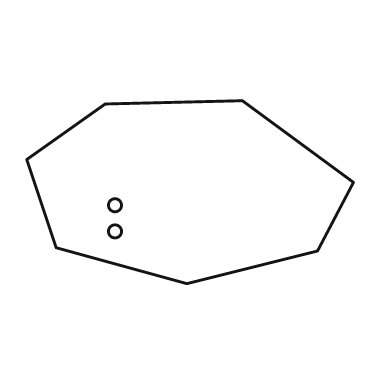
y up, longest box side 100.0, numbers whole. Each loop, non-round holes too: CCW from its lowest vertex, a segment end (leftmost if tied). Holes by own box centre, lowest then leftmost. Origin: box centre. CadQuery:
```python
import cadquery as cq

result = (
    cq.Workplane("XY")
    .moveTo(-1.0, -28.0)
    .lineTo(39.0, -18.0)
    .lineTo(50.0, 3.0)
    .lineTo(16.0, 28.0)
    .lineTo(-26.0, 27.0)
    .lineTo(-50.0, 10.0)
    .lineTo(-41.0, -17.0)
    .close()
    .moveTo(-23.0, -12.0)
    .circle(2.0)
    .moveTo(-23.0, -4.0)
    .circle(2.0)
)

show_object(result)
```